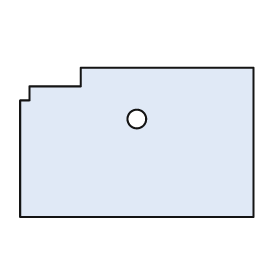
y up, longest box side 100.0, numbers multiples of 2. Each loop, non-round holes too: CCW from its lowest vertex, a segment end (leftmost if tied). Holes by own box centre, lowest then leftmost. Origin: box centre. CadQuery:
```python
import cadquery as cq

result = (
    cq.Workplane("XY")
    .moveTo(-50.0, -32.0)
    .lineTo(50.0, -32.0)
    .lineTo(50.0, 32.0)
    .lineTo(-24.0, 32.0)
    .lineTo(-24.0, 24.0)
    .lineTo(-46.0, 24.0)
    .lineTo(-46.0, 18.0)
    .lineTo(-50.0, 18.0)
    .close()
    .moveTo(0.0, 10.0)
    .circle(4.0)
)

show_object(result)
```